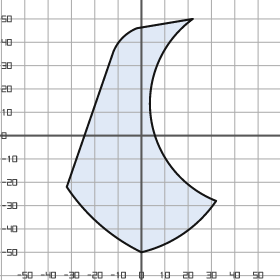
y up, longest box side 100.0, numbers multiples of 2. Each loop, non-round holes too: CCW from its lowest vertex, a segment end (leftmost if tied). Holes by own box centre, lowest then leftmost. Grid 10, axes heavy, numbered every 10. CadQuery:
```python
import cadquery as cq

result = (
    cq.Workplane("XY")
    .moveTo(0.0, -50.0)
    .threePointArc((18.0, -42.0), (32.0, -28.0))
    .threePointArc((4.0, 8.0), (22.0, 50.0))
    .lineTo(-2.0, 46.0)
    .threePointArc((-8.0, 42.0), (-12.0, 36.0))
    .lineTo(-32.0, -22.0)
    .threePointArc((-18.0, -38.0), (0.0, -50.0))
    .close()
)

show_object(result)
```